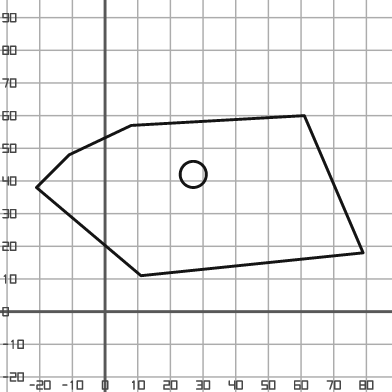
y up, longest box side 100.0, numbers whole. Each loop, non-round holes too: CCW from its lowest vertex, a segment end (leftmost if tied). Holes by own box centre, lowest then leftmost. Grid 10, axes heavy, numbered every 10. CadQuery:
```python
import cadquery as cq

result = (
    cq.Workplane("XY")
    .moveTo(11.0, 11.0)
    .lineTo(79.0, 18.0)
    .lineTo(61.0, 60.0)
    .lineTo(8.0, 57.0)
    .lineTo(-11.0, 48.0)
    .lineTo(-21.0, 38.0)
    .close()
    .moveTo(27.0, 42.0)
    .circle(4.0)
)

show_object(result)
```